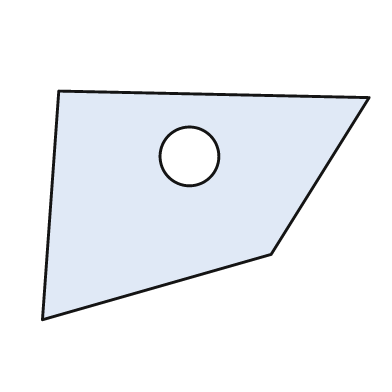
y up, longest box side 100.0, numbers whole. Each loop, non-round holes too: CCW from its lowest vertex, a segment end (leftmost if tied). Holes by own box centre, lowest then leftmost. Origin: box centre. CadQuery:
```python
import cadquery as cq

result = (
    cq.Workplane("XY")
    .moveTo(-50.0, -35.0)
    .lineTo(20.0, -15.0)
    .lineTo(50.0, 33.0)
    .lineTo(-45.0, 35.0)
    .close()
    .moveTo(-5.0, 15.0)
    .circle(9.0)
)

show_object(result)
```